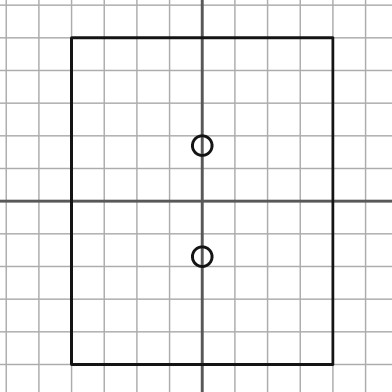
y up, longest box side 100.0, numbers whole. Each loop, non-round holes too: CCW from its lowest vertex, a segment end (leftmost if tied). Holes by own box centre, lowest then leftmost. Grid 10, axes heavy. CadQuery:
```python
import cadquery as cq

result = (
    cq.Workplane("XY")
    .moveTo(-40.0, -50.0)
    .lineTo(40.0, -50.0)
    .lineTo(40.0, 50.0)
    .lineTo(-40.0, 50.0)
    .close()
    .moveTo(0.0, -17.0)
    .circle(3.0)
    .moveTo(0.0, 17.0)
    .circle(3.0)
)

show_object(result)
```